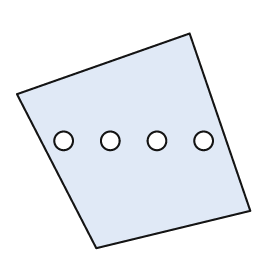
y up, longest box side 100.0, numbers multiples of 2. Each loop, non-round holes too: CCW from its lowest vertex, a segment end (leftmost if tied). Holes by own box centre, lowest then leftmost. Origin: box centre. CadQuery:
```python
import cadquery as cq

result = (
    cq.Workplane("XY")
    .moveTo(-16.0, -46.0)
    .lineTo(50.0, -30.0)
    .lineTo(24.0, 46.0)
    .lineTo(-50.0, 20.0)
    .close()
    .moveTo(-30.0, 0.0)
    .circle(4.0)
    .moveTo(-10.0, 0.0)
    .circle(4.0)
    .moveTo(10.0, 0.0)
    .circle(4.0)
    .moveTo(30.0, 0.0)
    .circle(4.0)
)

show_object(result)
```